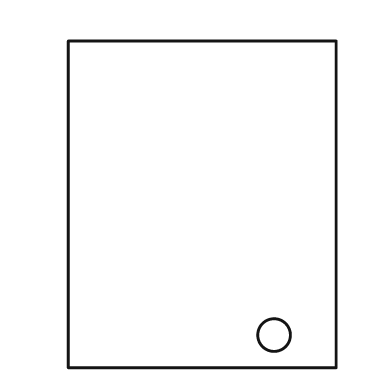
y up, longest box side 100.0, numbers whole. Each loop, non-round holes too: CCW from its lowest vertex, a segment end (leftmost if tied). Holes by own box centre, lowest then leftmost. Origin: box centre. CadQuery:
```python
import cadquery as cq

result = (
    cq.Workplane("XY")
    .moveTo(-41.0, -50.0)
    .lineTo(41.0, -50.0)
    .lineTo(41.0, 50.0)
    .lineTo(-41.0, 50.0)
    .close()
    .moveTo(22.0, -40.0)
    .circle(5.0)
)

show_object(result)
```